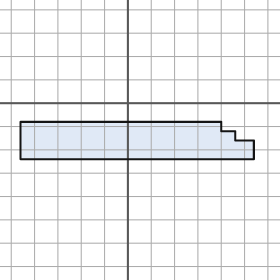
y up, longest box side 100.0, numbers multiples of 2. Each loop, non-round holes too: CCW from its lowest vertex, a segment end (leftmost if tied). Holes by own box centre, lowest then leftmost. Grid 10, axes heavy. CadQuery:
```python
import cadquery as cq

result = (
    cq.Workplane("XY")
    .moveTo(-46.0, -24.0)
    .lineTo(54.0, -24.0)
    .lineTo(54.0, -16.0)
    .lineTo(46.0, -16.0)
    .lineTo(46.0, -12.0)
    .lineTo(40.0, -12.0)
    .lineTo(40.0, -8.0)
    .lineTo(-46.0, -8.0)
    .close()
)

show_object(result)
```